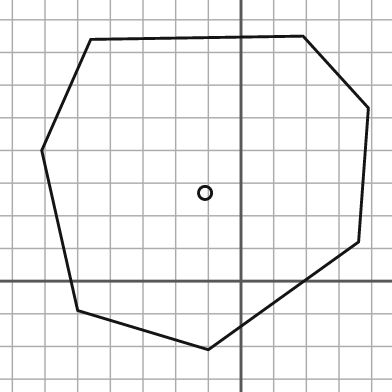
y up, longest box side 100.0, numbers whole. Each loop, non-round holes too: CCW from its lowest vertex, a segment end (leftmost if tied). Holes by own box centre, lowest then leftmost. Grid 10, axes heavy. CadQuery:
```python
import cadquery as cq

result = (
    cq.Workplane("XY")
    .moveTo(-10.0, -21.0)
    .lineTo(36.0, 12.0)
    .lineTo(39.0, 53.0)
    .lineTo(19.0, 75.0)
    .lineTo(-46.0, 74.0)
    .lineTo(-61.0, 40.0)
    .lineTo(-50.0, -9.0)
    .close()
    .moveTo(-11.0, 27.0)
    .circle(2.0)
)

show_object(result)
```